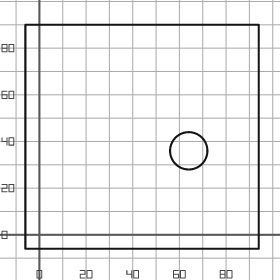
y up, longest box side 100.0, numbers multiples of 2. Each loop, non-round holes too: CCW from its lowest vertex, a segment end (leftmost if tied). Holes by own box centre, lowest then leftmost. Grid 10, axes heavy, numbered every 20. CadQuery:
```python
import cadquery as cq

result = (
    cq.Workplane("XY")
    .moveTo(-6.0, -6.0)
    .lineTo(94.0, -6.0)
    .lineTo(94.0, 90.0)
    .lineTo(-6.0, 90.0)
    .close()
    .moveTo(64.0, 36.0)
    .circle(8.0)
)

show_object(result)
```